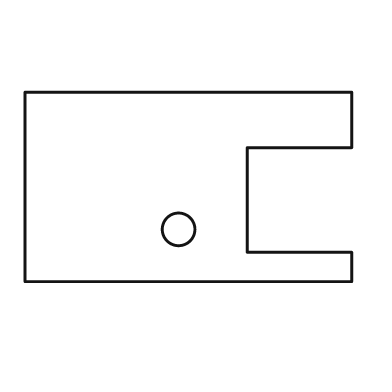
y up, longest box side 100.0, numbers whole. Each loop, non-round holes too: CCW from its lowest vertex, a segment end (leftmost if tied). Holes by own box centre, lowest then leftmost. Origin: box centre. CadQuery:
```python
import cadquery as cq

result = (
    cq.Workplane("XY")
    .moveTo(-50.0, -29.0)
    .lineTo(50.0, -29.0)
    .lineTo(50.0, -20.0)
    .lineTo(18.0, -20.0)
    .lineTo(18.0, 12.0)
    .lineTo(50.0, 12.0)
    .lineTo(50.0, 29.0)
    .lineTo(-50.0, 29.0)
    .close()
    .moveTo(-3.0, -13.0)
    .circle(5.0)
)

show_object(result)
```